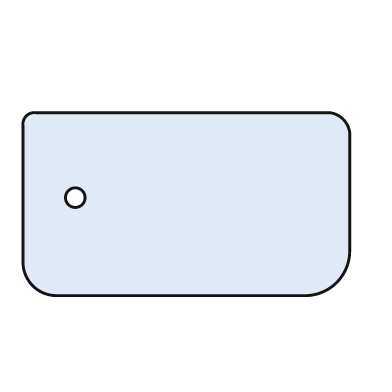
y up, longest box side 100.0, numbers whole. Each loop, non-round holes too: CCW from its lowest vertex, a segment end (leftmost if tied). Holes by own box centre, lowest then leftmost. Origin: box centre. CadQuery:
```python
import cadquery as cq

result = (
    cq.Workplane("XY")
    .moveTo(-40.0, -28.0)
    .lineTo(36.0, -28.0)
    .threePointArc((46.0, -24.0), (50.0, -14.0))
    .lineTo(50.0, 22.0)
    .threePointArc((48.0, 26.0), (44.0, 28.0))
    .lineTo(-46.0, 28.0)
    .threePointArc((-49.0, 27.0), (-50.0, 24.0))
    .lineTo(-50.0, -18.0)
    .threePointArc((-47.0, -25.0), (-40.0, -28.0))
    .close()
    .moveTo(-34.0, 2.0)
    .circle(3.0)
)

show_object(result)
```